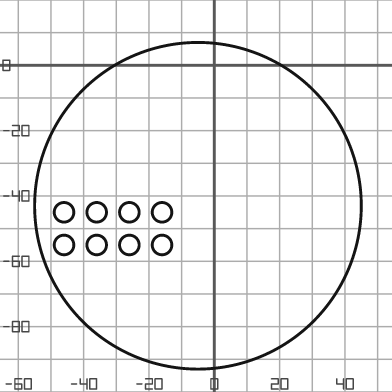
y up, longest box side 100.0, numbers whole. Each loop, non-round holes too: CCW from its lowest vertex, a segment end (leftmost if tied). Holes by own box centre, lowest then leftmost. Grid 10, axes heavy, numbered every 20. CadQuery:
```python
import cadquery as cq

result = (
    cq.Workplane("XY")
    .moveTo(-5.0, -43.0)
    .circle(50.0)
    .moveTo(-46.0, -55.0)
    .circle(3.0)
    .moveTo(-36.0, -55.0)
    .circle(3.0)
    .moveTo(-26.0, -55.0)
    .circle(3.0)
    .moveTo(-16.0, -55.0)
    .circle(3.0)
    .moveTo(-46.0, -45.0)
    .circle(3.0)
    .moveTo(-36.0, -45.0)
    .circle(3.0)
    .moveTo(-26.0, -45.0)
    .circle(3.0)
    .moveTo(-16.0, -45.0)
    .circle(3.0)
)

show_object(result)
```